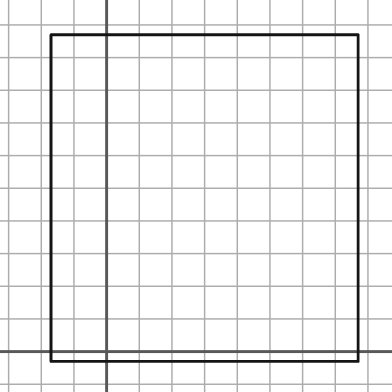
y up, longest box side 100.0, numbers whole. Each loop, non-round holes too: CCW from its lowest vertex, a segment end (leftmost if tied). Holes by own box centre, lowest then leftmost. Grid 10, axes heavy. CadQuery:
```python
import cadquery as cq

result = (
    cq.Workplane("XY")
    .moveTo(-17.0, -3.0)
    .lineTo(77.0, -3.0)
    .lineTo(77.0, 97.0)
    .lineTo(-17.0, 97.0)
    .close()
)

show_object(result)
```